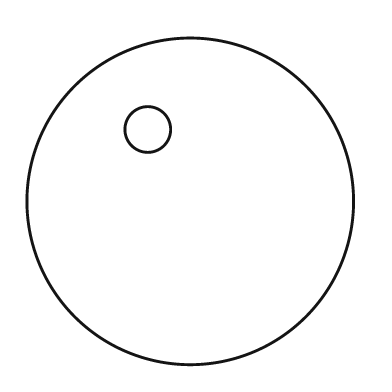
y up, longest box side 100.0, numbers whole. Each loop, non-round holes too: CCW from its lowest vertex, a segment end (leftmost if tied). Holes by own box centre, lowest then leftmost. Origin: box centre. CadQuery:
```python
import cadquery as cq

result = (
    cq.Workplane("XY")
    .moveTo(0.0, 0.0)
    .circle(50.0)
    .moveTo(-13.0, 22.0)
    .circle(7.0)
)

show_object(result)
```